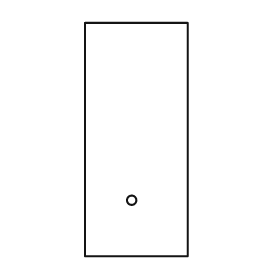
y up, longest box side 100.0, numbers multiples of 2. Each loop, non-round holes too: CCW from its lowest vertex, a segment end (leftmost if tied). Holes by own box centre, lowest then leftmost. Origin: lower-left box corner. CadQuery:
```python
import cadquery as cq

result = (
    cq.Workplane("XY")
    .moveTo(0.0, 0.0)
    .lineTo(44.0, 0.0)
    .lineTo(44.0, 100.0)
    .lineTo(0.0, 100.0)
    .close()
    .moveTo(20.0, 24.0)
    .circle(2.0)
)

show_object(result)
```